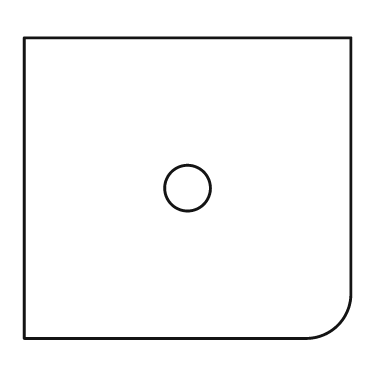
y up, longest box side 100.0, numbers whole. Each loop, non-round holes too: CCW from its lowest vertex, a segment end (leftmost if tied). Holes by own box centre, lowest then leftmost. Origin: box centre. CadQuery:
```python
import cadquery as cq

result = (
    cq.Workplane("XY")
    .moveTo(-50.0, -46.0)
    .lineTo(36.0, -46.0)
    .threePointArc((46.0, -42.0), (50.0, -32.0))
    .lineTo(50.0, 46.0)
    .lineTo(-50.0, 46.0)
    .close()
    .moveTo(0.0, 0.0)
    .circle(7.0)
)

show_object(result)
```